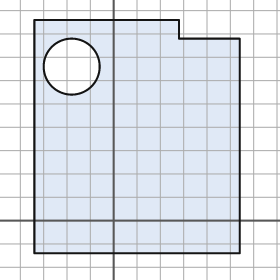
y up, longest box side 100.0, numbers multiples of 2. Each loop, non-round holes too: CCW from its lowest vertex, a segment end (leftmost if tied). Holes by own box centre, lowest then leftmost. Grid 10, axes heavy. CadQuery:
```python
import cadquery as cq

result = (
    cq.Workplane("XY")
    .moveTo(-34.0, -14.0)
    .lineTo(54.0, -14.0)
    .lineTo(54.0, 78.0)
    .lineTo(28.0, 78.0)
    .lineTo(28.0, 86.0)
    .lineTo(-34.0, 86.0)
    .close()
    .moveTo(-18.0, 66.0)
    .circle(12.0)
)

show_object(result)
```